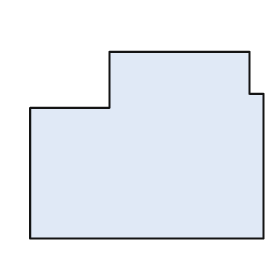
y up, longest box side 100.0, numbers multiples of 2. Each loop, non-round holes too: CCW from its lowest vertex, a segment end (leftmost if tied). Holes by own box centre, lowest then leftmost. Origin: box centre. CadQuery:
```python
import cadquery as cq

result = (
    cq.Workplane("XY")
    .moveTo(-50.0, -40.0)
    .lineTo(50.0, -40.0)
    .lineTo(50.0, 22.0)
    .lineTo(44.0, 22.0)
    .lineTo(44.0, 40.0)
    .lineTo(-16.0, 40.0)
    .lineTo(-16.0, 16.0)
    .lineTo(-50.0, 16.0)
    .close()
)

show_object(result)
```